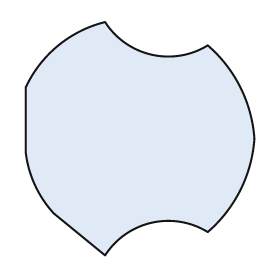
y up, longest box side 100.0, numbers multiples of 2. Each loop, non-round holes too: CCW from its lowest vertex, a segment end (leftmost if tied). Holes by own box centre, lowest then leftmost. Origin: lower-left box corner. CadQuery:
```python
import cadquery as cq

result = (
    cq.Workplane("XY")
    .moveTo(34.0, 0.0)
    .threePointArc((54.0, 14.0), (78.0, 10.0))
    .threePointArc((92.0, 28.0), (98.0, 50.0))
    .threePointArc((92.0, 72.0), (78.0, 90.0))
    .threePointArc((54.0, 86.0), (34.0, 100.0))
    .threePointArc((14.0, 90.0), (0.0, 72.0))
    .lineTo(0.0, 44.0)
    .threePointArc((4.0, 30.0), (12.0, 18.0))
    .close()
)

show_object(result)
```